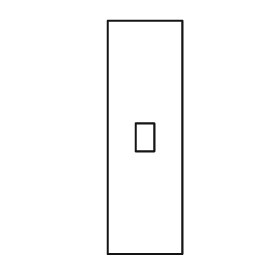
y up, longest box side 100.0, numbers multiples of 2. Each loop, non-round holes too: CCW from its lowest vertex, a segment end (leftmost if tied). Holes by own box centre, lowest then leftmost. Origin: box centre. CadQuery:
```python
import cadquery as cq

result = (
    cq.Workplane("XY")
    .moveTo(-16.0, -50.0)
    .lineTo(16.0, -50.0)
    .lineTo(16.0, 50.0)
    .lineTo(-16.0, 50.0)
    .close()
    .moveTo(-4.0, -6.0)
    .lineTo(4.0, -6.0)
    .lineTo(4.0, 6.0)
    .lineTo(-4.0, 6.0)
    .close()
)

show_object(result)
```